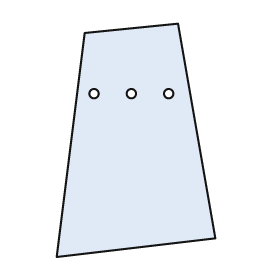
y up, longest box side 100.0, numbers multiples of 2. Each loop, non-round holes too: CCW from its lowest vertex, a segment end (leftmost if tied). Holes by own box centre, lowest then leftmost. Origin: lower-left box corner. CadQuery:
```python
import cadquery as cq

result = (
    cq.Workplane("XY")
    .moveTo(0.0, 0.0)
    .lineTo(68.0, 8.0)
    .lineTo(52.0, 100.0)
    .lineTo(12.0, 96.0)
    .close()
    .moveTo(16.0, 70.0)
    .circle(2.0)
    .moveTo(32.0, 70.0)
    .circle(2.0)
    .moveTo(48.0, 70.0)
    .circle(2.0)
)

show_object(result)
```